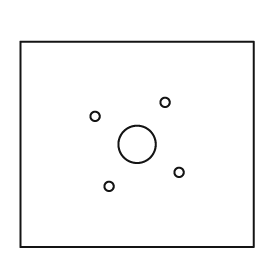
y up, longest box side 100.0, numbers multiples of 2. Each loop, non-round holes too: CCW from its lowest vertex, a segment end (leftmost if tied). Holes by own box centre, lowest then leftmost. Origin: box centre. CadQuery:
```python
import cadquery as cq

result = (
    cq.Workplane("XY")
    .moveTo(-50.0, -44.0)
    .lineTo(50.0, -44.0)
    .lineTo(50.0, 44.0)
    .lineTo(-50.0, 44.0)
    .close()
    .moveTo(-12.0, -18.0)
    .circle(2.0)
    .moveTo(18.0, -12.0)
    .circle(2.0)
    .moveTo(0.0, 0.0)
    .circle(8.0)
    .moveTo(-18.0, 12.0)
    .circle(2.0)
    .moveTo(12.0, 18.0)
    .circle(2.0)
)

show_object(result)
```